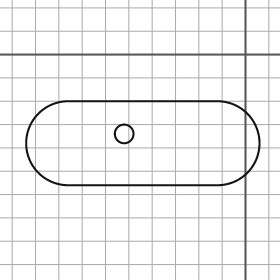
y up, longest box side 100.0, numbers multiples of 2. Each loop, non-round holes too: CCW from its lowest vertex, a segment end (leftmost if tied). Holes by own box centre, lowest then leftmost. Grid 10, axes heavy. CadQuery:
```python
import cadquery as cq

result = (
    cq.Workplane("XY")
    .moveTo(-76.0, -56.0)
    .lineTo(-12.0, -56.0)
    .threePointArc((6.0, -38.0), (-12.0, -20.0))
    .lineTo(-76.0, -20.0)
    .threePointArc((-94.0, -38.0), (-76.0, -56.0))
    .close()
    .moveTo(-52.0, -34.0)
    .circle(4.0)
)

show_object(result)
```